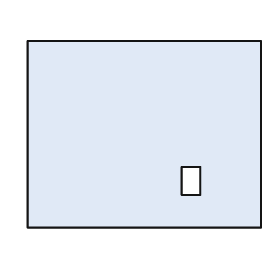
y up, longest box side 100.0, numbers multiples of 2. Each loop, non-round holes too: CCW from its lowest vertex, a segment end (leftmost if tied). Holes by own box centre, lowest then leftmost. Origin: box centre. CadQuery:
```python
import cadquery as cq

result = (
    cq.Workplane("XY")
    .moveTo(-50.0, -40.0)
    .lineTo(50.0, -40.0)
    .lineTo(50.0, 40.0)
    .lineTo(-50.0, 40.0)
    .close()
    .moveTo(16.0, -26.0)
    .lineTo(24.0, -26.0)
    .lineTo(24.0, -14.0)
    .lineTo(16.0, -14.0)
    .close()
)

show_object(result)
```